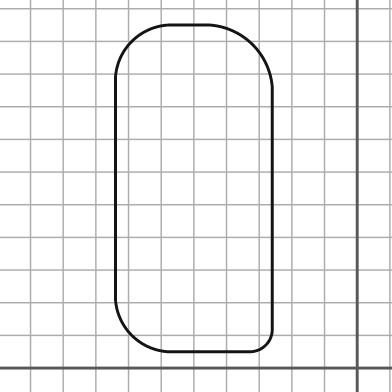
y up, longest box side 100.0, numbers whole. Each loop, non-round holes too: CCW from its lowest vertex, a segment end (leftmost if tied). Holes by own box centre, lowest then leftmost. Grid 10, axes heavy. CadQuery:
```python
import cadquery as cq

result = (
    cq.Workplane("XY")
    .moveTo(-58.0, 5.0)
    .lineTo(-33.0, 5.0)
    .threePointArc((-28.0, 7.0), (-26.0, 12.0))
    .lineTo(-26.0, 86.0)
    .threePointArc((-32.0, 99.0), (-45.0, 105.0))
    .lineTo(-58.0, 105.0)
    .threePointArc((-69.0, 100.0), (-74.0, 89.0))
    .lineTo(-74.0, 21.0)
    .threePointArc((-69.0, 10.0), (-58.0, 5.0))
    .close()
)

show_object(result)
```